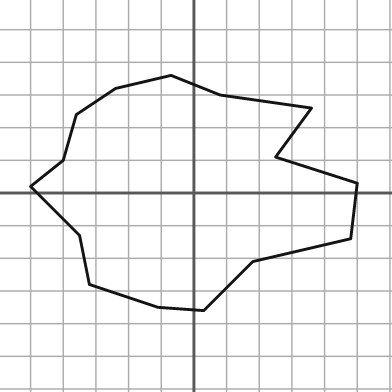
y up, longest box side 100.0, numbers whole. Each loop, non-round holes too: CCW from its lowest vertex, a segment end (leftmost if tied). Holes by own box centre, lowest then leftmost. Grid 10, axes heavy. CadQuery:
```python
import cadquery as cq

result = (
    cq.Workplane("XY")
    .moveTo(3.0, -36.0)
    .lineTo(18.0, -21.0)
    .lineTo(48.0, -14.0)
    .lineTo(50.0, 3.0)
    .lineTo(25.0, 11.0)
    .lineTo(36.0, 26.0)
    .lineTo(8.0, 30.0)
    .lineTo(-7.0, 36.0)
    .lineTo(-24.0, 32.0)
    .lineTo(-36.0, 24.0)
    .lineTo(-40.0, 10.0)
    .lineTo(-50.0, 2.0)
    .lineTo(-35.0, -13.0)
    .lineTo(-32.0, -28.0)
    .lineTo(-11.0, -35.0)
    .close()
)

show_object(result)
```